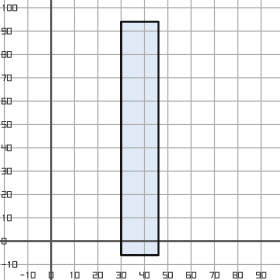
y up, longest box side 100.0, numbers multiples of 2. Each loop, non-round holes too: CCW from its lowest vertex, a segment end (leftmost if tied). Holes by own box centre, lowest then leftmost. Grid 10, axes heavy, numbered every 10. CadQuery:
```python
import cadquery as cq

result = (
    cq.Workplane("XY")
    .moveTo(30.0, -6.0)
    .lineTo(46.0, -6.0)
    .lineTo(46.0, 94.0)
    .lineTo(30.0, 94.0)
    .close()
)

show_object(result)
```